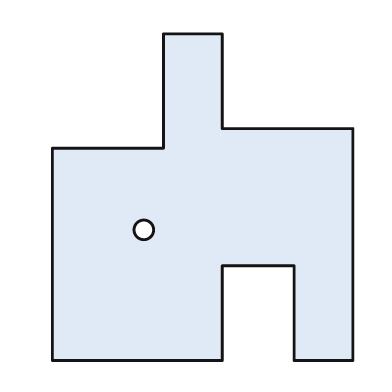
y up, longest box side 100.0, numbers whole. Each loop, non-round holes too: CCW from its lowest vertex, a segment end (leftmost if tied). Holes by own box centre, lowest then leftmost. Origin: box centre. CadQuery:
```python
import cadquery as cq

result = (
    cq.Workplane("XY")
    .moveTo(-46.0, -50.0)
    .lineTo(6.0, -50.0)
    .lineTo(6.0, -21.0)
    .lineTo(28.0, -21.0)
    .lineTo(28.0, -50.0)
    .lineTo(46.0, -50.0)
    .lineTo(46.0, 21.0)
    .lineTo(6.0, 21.0)
    .lineTo(6.0, 50.0)
    .lineTo(-12.0, 50.0)
    .lineTo(-12.0, 15.0)
    .lineTo(-46.0, 15.0)
    .close()
    .moveTo(-18.0, -10.0)
    .circle(3.0)
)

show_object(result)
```